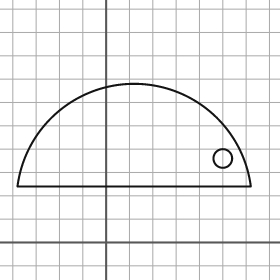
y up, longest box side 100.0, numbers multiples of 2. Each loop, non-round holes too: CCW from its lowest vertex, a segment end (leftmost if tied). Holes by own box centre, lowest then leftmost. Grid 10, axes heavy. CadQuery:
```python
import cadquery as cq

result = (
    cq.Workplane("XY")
    .moveTo(-38.0, 24.0)
    .lineTo(62.0, 24.0)
    .threePointArc((12.0, 68.0), (-38.0, 24.0))
    .close()
    .moveTo(50.0, 36.0)
    .circle(4.0)
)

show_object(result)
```